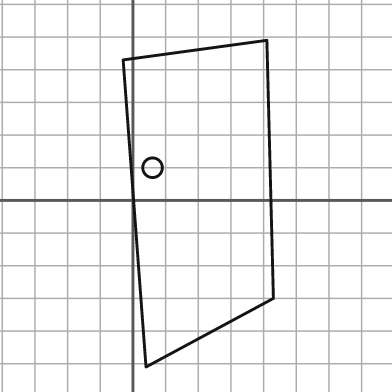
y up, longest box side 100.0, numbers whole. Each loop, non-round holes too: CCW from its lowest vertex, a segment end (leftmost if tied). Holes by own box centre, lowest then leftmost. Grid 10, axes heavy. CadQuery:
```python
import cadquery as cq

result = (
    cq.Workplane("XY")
    .moveTo(4.0, -51.0)
    .lineTo(43.0, -30.0)
    .lineTo(41.0, 49.0)
    .lineTo(-3.0, 43.0)
    .close()
    .moveTo(6.0, 10.0)
    .circle(3.0)
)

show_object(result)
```